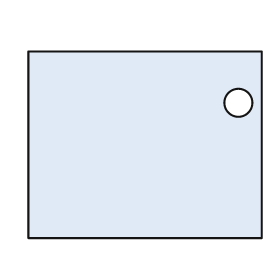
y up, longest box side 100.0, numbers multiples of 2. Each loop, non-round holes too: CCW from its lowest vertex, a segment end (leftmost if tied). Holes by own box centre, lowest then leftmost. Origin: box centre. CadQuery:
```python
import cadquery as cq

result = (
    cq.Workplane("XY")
    .moveTo(-50.0, -40.0)
    .lineTo(50.0, -40.0)
    .lineTo(50.0, 40.0)
    .lineTo(-50.0, 40.0)
    .close()
    .moveTo(40.0, 18.0)
    .circle(6.0)
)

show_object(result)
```